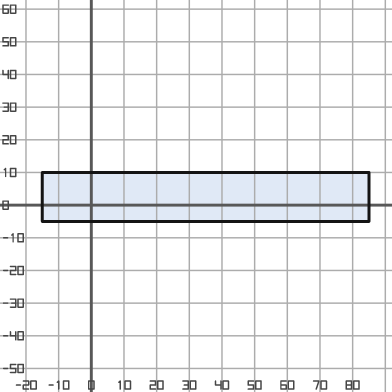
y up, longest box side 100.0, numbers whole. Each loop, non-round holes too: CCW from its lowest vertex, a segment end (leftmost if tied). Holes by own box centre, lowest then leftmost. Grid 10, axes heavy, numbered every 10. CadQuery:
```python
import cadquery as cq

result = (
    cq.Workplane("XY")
    .moveTo(-15.0, -5.0)
    .lineTo(85.0, -5.0)
    .lineTo(85.0, 10.0)
    .lineTo(-15.0, 10.0)
    .close()
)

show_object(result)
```